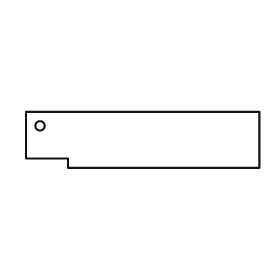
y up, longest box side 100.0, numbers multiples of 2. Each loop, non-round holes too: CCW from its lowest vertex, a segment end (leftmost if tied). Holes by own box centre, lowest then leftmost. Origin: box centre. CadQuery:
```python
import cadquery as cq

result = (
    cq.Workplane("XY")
    .moveTo(-32.0, -12.0)
    .lineTo(50.0, -12.0)
    .lineTo(50.0, 12.0)
    .lineTo(-50.0, 12.0)
    .lineTo(-50.0, -8.0)
    .lineTo(-32.0, -8.0)
    .close()
    .moveTo(-44.0, 6.0)
    .circle(2.0)
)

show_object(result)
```